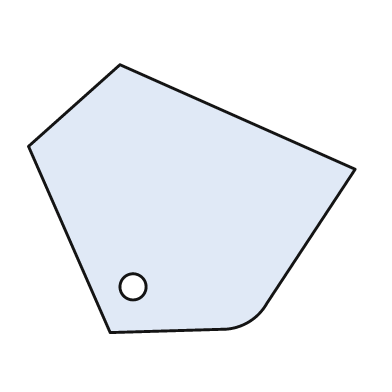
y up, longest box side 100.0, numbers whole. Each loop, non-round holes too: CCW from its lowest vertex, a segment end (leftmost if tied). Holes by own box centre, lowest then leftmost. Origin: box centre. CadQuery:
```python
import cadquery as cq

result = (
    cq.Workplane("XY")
    .moveTo(-25.0, -41.0)
    .lineTo(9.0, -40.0)
    .threePointArc((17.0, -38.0), (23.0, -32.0))
    .lineTo(50.0, 9.0)
    .lineTo(-22.0, 41.0)
    .lineTo(-50.0, 16.0)
    .close()
    .moveTo(-18.0, -27.0)
    .circle(4.0)
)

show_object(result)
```